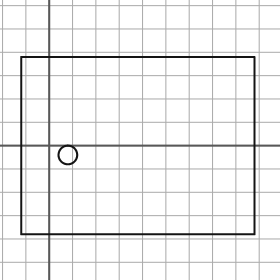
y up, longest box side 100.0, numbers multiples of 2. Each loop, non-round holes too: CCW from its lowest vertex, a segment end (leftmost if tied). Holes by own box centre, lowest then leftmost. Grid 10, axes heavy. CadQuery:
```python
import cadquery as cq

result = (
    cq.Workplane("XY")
    .moveTo(-12.0, -38.0)
    .lineTo(88.0, -38.0)
    .lineTo(88.0, 38.0)
    .lineTo(-12.0, 38.0)
    .close()
    .moveTo(8.0, -4.0)
    .circle(4.0)
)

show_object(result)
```